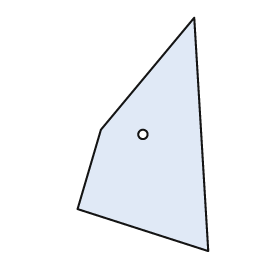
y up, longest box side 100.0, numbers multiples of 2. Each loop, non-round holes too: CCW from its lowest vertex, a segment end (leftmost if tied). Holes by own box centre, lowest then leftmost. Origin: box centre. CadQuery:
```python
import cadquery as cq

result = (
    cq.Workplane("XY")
    .moveTo(28.0, -50.0)
    .lineTo(22.0, 50.0)
    .lineTo(-18.0, 2.0)
    .lineTo(-28.0, -32.0)
    .close()
    .moveTo(0.0, 0.0)
    .circle(2.0)
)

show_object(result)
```